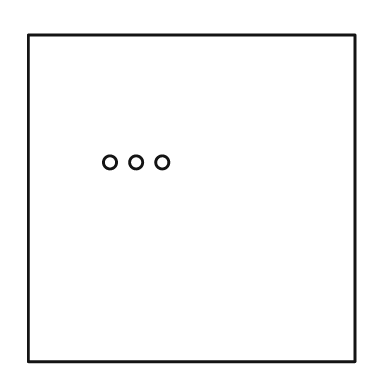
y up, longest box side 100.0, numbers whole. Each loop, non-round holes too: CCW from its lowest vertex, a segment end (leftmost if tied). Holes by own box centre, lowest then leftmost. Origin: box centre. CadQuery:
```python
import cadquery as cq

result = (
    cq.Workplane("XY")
    .moveTo(-50.0, -50.0)
    .lineTo(50.0, -50.0)
    .lineTo(50.0, 50.0)
    .lineTo(-50.0, 50.0)
    .close()
    .moveTo(-25.0, 11.0)
    .circle(2.0)
    .moveTo(-17.0, 11.0)
    .circle(2.0)
    .moveTo(-9.0, 11.0)
    .circle(2.0)
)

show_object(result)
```